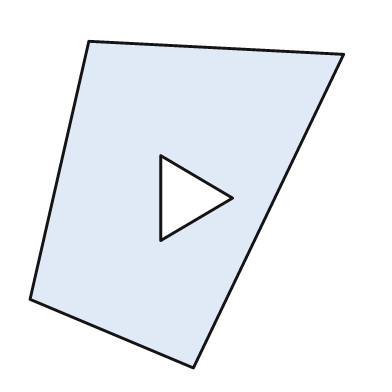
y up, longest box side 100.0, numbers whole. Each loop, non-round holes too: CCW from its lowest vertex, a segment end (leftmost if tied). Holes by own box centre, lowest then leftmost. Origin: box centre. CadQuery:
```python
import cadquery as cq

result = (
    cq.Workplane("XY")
    .moveTo(2.0, -50.0)
    .lineTo(48.0, 46.0)
    .lineTo(-30.0, 50.0)
    .lineTo(-48.0, -29.0)
    .close()
    .moveTo(-8.0, -11.0)
    .lineTo(14.0, 2.0)
    .lineTo(-8.0, 15.0)
    .close()
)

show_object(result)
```